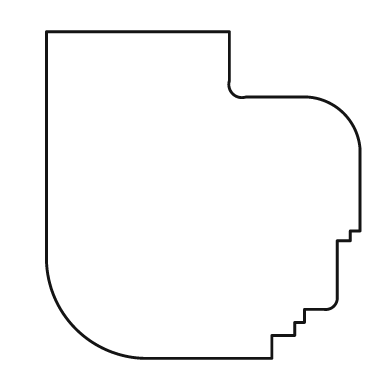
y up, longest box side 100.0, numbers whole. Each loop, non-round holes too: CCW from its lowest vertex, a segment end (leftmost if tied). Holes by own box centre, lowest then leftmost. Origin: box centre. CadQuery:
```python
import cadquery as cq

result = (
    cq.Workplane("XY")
    .moveTo(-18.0, -50.0)
    .lineTo(21.0, -50.0)
    .lineTo(21.0, -43.0)
    .lineTo(28.0, -43.0)
    .lineTo(28.0, -39.0)
    .lineTo(31.0, -39.0)
    .lineTo(31.0, -35.0)
    .lineTo(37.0, -35.0)
    .threePointArc((40.0, -34.0), (41.0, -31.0))
    .lineTo(41.0, -14.0)
    .lineTo(45.0, -14.0)
    .lineTo(45.0, -11.0)
    .lineTo(48.0, -11.0)
    .lineTo(48.0, 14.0)
    .threePointArc((43.0, 25.0), (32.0, 30.0))
    .lineTo(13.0, 30.0)
    .threePointArc((9.0, 31.0), (8.0, 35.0))
    .lineTo(8.0, 50.0)
    .lineTo(-48.0, 50.0)
    .lineTo(-48.0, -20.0)
    .threePointArc((-39.0, -41.0), (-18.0, -50.0))
    .close()
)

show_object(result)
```